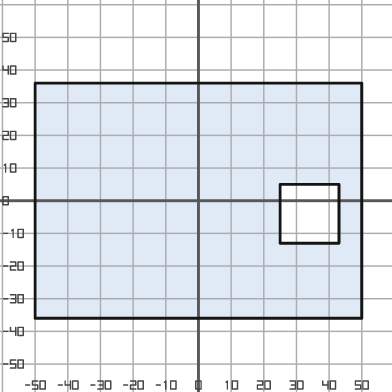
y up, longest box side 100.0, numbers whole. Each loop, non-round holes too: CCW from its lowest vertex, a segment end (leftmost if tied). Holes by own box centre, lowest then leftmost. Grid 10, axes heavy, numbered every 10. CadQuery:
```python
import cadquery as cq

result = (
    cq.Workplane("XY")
    .moveTo(-50.0, -36.0)
    .lineTo(50.0, -36.0)
    .lineTo(50.0, 36.0)
    .lineTo(-50.0, 36.0)
    .close()
    .moveTo(25.0, -13.0)
    .lineTo(43.0, -13.0)
    .lineTo(43.0, 5.0)
    .lineTo(25.0, 5.0)
    .close()
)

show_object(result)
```